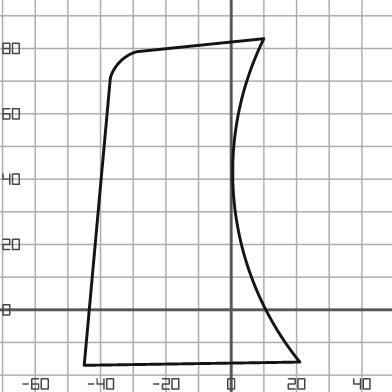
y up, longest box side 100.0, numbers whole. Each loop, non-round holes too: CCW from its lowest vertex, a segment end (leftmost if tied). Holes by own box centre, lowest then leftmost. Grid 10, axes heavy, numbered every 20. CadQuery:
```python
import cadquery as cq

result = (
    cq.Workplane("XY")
    .moveTo(-45.0, -17.0)
    .lineTo(21.0, -16.0)
    .threePointArc((1.0, 32.0), (10.0, 83.0))
    .lineTo(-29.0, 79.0)
    .threePointArc((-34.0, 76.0), (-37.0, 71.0))
    .close()
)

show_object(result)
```